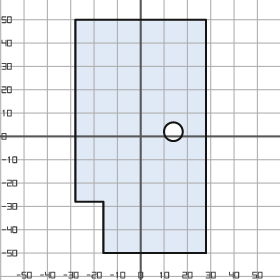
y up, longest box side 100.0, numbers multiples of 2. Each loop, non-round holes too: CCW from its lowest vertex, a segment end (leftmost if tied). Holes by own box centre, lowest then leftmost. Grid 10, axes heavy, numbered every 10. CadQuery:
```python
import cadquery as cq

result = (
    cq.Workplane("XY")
    .moveTo(-16.0, -50.0)
    .lineTo(28.0, -50.0)
    .lineTo(28.0, 50.0)
    .lineTo(-28.0, 50.0)
    .lineTo(-28.0, -28.0)
    .lineTo(-16.0, -28.0)
    .close()
    .moveTo(14.0, 2.0)
    .circle(4.0)
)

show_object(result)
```